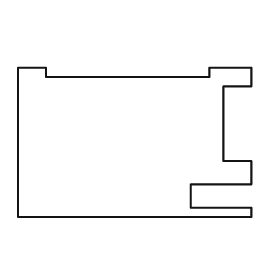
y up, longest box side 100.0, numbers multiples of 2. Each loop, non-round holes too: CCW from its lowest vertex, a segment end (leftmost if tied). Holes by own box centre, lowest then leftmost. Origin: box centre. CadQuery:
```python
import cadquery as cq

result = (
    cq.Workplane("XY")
    .moveTo(-50.0, -32.0)
    .lineTo(50.0, -32.0)
    .lineTo(50.0, -28.0)
    .lineTo(24.0, -28.0)
    .lineTo(24.0, -18.0)
    .lineTo(50.0, -18.0)
    .lineTo(50.0, -8.0)
    .lineTo(38.0, -8.0)
    .lineTo(38.0, 24.0)
    .lineTo(50.0, 24.0)
    .lineTo(50.0, 32.0)
    .lineTo(32.0, 32.0)
    .lineTo(32.0, 28.0)
    .lineTo(-38.0, 28.0)
    .lineTo(-38.0, 32.0)
    .lineTo(-50.0, 32.0)
    .close()
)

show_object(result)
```